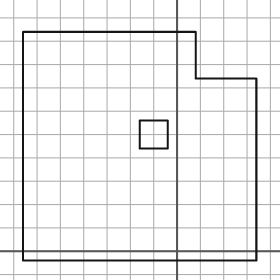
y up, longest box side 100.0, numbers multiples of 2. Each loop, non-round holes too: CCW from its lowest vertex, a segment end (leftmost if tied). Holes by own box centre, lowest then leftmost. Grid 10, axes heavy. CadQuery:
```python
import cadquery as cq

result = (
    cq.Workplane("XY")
    .moveTo(-66.0, -4.0)
    .lineTo(34.0, -4.0)
    .lineTo(34.0, 74.0)
    .lineTo(8.0, 74.0)
    .lineTo(8.0, 94.0)
    .lineTo(-66.0, 94.0)
    .close()
    .moveTo(-16.0, 44.0)
    .lineTo(-4.0, 44.0)
    .lineTo(-4.0, 56.0)
    .lineTo(-16.0, 56.0)
    .close()
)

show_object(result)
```